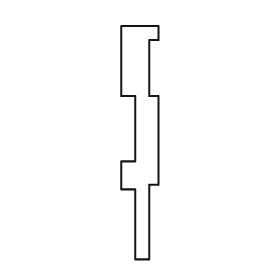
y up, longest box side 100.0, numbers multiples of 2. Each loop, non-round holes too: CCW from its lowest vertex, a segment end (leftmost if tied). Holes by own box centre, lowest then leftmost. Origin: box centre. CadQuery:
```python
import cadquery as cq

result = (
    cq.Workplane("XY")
    .moveTo(-2.0, -50.0)
    .lineTo(4.0, -50.0)
    .lineTo(4.0, -18.0)
    .lineTo(8.0, -18.0)
    .lineTo(8.0, 20.0)
    .lineTo(4.0, 20.0)
    .lineTo(4.0, 44.0)
    .lineTo(8.0, 44.0)
    .lineTo(8.0, 50.0)
    .lineTo(-8.0, 50.0)
    .lineTo(-8.0, 20.0)
    .lineTo(-2.0, 20.0)
    .lineTo(-2.0, -8.0)
    .lineTo(-8.0, -8.0)
    .lineTo(-8.0, -20.0)
    .lineTo(-2.0, -20.0)
    .close()
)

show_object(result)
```